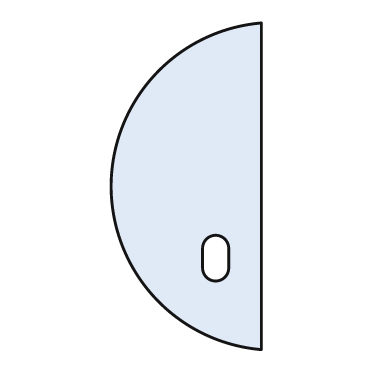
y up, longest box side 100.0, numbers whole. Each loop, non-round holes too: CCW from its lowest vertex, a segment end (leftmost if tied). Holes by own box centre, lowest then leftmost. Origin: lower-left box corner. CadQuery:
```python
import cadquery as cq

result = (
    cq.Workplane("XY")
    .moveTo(46.0, 0.0)
    .lineTo(46.0, 100.0)
    .threePointArc((0.0, 50.0), (46.0, 0.0))
    .close()
    .moveTo(28.0, 25.0)
    .threePointArc((32.0, 21.0), (36.0, 25.0))
    .lineTo(36.0, 31.0)
    .threePointArc((32.0, 35.0), (28.0, 31.0))
    .close()
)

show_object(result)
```